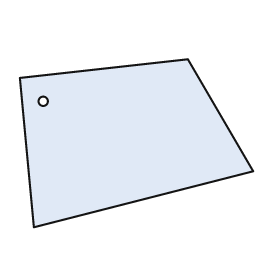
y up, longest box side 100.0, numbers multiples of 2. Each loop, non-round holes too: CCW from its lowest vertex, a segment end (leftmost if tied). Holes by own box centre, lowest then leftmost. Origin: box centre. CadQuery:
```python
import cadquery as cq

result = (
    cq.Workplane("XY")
    .moveTo(-44.0, -36.0)
    .lineTo(50.0, -12.0)
    .lineTo(22.0, 36.0)
    .lineTo(-50.0, 28.0)
    .close()
    .moveTo(-40.0, 18.0)
    .circle(2.0)
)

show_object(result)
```